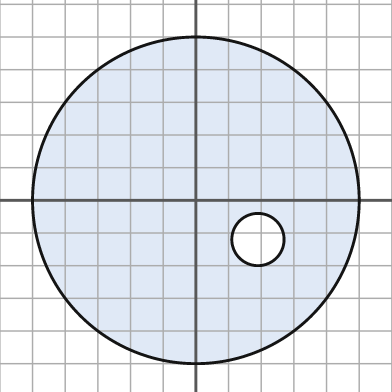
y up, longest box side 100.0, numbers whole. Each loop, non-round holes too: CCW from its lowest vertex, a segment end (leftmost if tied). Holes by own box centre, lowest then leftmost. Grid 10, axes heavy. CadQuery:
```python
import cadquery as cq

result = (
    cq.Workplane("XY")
    .moveTo(0.0, 0.0)
    .circle(50.0)
    .moveTo(19.0, -12.0)
    .circle(8.0)
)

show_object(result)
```